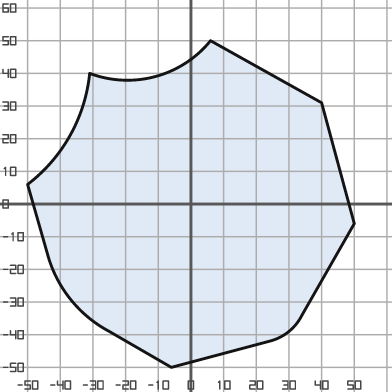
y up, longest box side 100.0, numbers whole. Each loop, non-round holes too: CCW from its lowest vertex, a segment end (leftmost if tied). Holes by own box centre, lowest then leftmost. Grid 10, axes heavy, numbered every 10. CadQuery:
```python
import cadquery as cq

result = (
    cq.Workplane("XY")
    .moveTo(-6.0, -50.0)
    .lineTo(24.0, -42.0)
    .threePointArc((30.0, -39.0), (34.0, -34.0))
    .lineTo(50.0, -6.0)
    .lineTo(40.0, 31.0)
    .lineTo(6.0, 50.0)
    .threePointArc((-11.0, 39.0), (-31.0, 40.0))
    .threePointArc((-37.0, 21.0), (-50.0, 6.0))
    .lineTo(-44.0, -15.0)
    .threePointArc((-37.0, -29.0), (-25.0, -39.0))
    .close()
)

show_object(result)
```